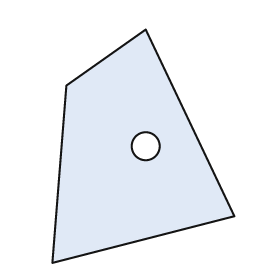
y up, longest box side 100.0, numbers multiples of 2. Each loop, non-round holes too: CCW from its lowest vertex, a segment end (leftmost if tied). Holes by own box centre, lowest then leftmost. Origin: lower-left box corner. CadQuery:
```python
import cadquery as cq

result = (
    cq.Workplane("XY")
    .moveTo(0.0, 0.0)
    .lineTo(78.0, 20.0)
    .lineTo(40.0, 100.0)
    .lineTo(6.0, 76.0)
    .close()
    .moveTo(40.0, 50.0)
    .circle(6.0)
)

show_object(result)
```